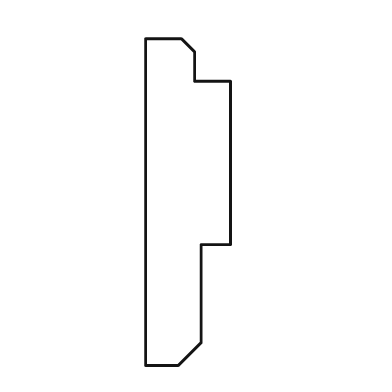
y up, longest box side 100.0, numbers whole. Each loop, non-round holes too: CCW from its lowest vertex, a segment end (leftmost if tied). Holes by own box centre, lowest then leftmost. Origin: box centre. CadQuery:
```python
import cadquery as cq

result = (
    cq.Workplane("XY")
    .moveTo(-13.0, -50.0)
    .lineTo(-3.0, -50.0)
    .lineTo(4.0, -43.0)
    .lineTo(4.0, -13.0)
    .lineTo(13.0, -13.0)
    .lineTo(13.0, 37.0)
    .lineTo(2.0, 37.0)
    .lineTo(2.0, 46.0)
    .lineTo(-2.0, 50.0)
    .lineTo(-13.0, 50.0)
    .close()
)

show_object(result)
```